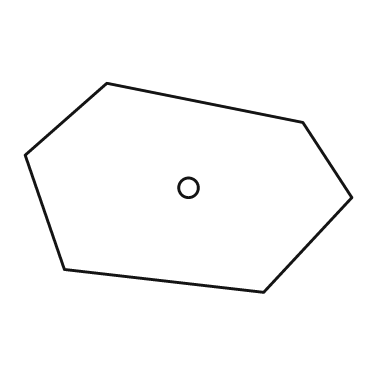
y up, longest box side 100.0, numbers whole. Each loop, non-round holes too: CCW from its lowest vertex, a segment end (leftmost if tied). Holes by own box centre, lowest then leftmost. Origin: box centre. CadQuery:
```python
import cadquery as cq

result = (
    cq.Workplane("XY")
    .moveTo(23.0, -32.0)
    .lineTo(50.0, -3.0)
    .lineTo(35.0, 20.0)
    .lineTo(-25.0, 32.0)
    .lineTo(-50.0, 10.0)
    .lineTo(-38.0, -25.0)
    .close()
    .moveTo(0.0, 0.0)
    .circle(3.0)
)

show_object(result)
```